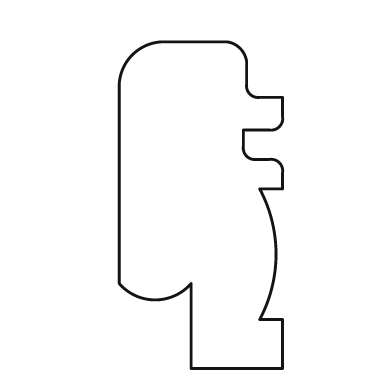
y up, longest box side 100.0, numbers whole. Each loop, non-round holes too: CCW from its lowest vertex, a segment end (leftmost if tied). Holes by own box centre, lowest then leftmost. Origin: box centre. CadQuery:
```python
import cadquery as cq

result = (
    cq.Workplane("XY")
    .moveTo(-3.0, -50.0)
    .lineTo(25.0, -50.0)
    .lineTo(25.0, -35.0)
    .lineTo(18.0, -35.0)
    .threePointArc((23.0, -15.0), (18.0, 5.0))
    .lineTo(25.0, 5.0)
    .lineTo(25.0, 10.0)
    .threePointArc((24.0, 13.0), (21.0, 14.0))
    .lineTo(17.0, 14.0)
    .threePointArc((14.0, 15.0), (13.0, 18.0))
    .lineTo(13.0, 23.0)
    .lineTo(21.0, 23.0)
    .threePointArc((24.0, 24.0), (25.0, 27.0))
    .lineTo(25.0, 33.0)
    .lineTo(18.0, 33.0)
    .threePointArc((15.0, 34.0), (14.0, 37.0))
    .lineTo(14.0, 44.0)
    .threePointArc((12.0, 48.0), (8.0, 50.0))
    .lineTo(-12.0, 50.0)
    .threePointArc((-21.0, 46.0), (-25.0, 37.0))
    .lineTo(-25.0, -24.0)
    .threePointArc((-14.0, -29.0), (-3.0, -24.0))
    .close()
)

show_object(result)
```